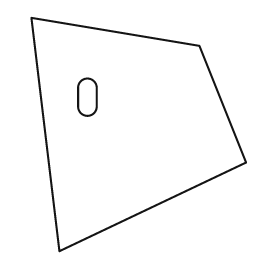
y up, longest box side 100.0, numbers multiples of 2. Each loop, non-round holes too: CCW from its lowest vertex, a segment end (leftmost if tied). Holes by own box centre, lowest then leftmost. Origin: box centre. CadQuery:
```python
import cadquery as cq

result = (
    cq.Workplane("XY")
    .moveTo(-34.0, -50.0)
    .lineTo(46.0, -12.0)
    .lineTo(26.0, 38.0)
    .lineTo(-46.0, 50.0)
    .close()
    .moveTo(-26.0, 12.0)
    .threePointArc((-22.0, 8.0), (-18.0, 12.0))
    .lineTo(-18.0, 20.0)
    .threePointArc((-22.0, 24.0), (-26.0, 20.0))
    .close()
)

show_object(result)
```